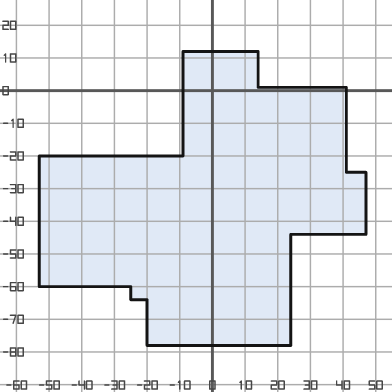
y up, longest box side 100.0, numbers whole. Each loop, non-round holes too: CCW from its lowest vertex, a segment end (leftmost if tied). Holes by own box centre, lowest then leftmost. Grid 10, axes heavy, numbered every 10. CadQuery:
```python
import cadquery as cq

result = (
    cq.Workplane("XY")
    .moveTo(-20.0, -78.0)
    .lineTo(24.0, -78.0)
    .lineTo(24.0, -44.0)
    .lineTo(47.0, -44.0)
    .lineTo(47.0, -25.0)
    .lineTo(41.0, -25.0)
    .lineTo(41.0, 1.0)
    .lineTo(14.0, 1.0)
    .lineTo(14.0, 12.0)
    .lineTo(-9.0, 12.0)
    .lineTo(-9.0, -20.0)
    .lineTo(-53.0, -20.0)
    .lineTo(-53.0, -60.0)
    .lineTo(-25.0, -60.0)
    .lineTo(-25.0, -64.0)
    .lineTo(-20.0, -64.0)
    .close()
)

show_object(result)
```